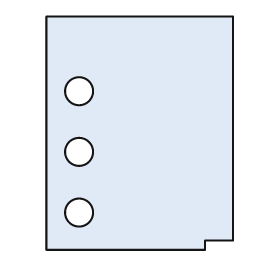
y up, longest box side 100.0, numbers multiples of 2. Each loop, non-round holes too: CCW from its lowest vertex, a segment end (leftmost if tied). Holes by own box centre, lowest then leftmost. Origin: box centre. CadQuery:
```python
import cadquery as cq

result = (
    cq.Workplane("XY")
    .moveTo(-40.0, -50.0)
    .lineTo(28.0, -50.0)
    .lineTo(28.0, -46.0)
    .lineTo(40.0, -46.0)
    .lineTo(40.0, 50.0)
    .lineTo(-40.0, 50.0)
    .close()
    .moveTo(-26.0, -34.0)
    .circle(6.0)
    .moveTo(-26.0, -8.0)
    .circle(6.0)
    .moveTo(-26.0, 18.0)
    .circle(6.0)
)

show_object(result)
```